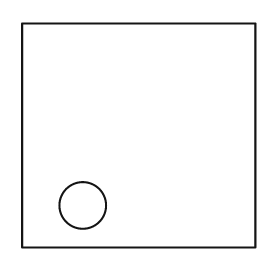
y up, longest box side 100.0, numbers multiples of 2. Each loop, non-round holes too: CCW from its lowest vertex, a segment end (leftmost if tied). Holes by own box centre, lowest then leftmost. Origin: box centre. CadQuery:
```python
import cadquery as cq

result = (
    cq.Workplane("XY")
    .moveTo(-50.0, -48.0)
    .lineTo(50.0, -48.0)
    .lineTo(50.0, 48.0)
    .lineTo(-50.0, 48.0)
    .close()
    .moveTo(-24.0, -30.0)
    .circle(10.0)
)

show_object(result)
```